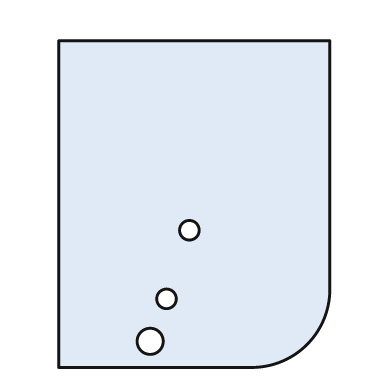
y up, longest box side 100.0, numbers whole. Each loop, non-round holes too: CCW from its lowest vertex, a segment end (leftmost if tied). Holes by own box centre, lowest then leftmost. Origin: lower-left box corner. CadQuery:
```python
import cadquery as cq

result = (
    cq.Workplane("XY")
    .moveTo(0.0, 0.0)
    .lineTo(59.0, 0.0)
    .threePointArc((76.0, 7.0), (83.0, 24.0))
    .lineTo(83.0, 100.0)
    .lineTo(0.0, 100.0)
    .close()
    .moveTo(28.0, 8.0)
    .circle(4.0)
    .moveTo(33.0, 21.0)
    .circle(3.0)
    .moveTo(40.0, 42.0)
    .circle(3.0)
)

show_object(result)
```